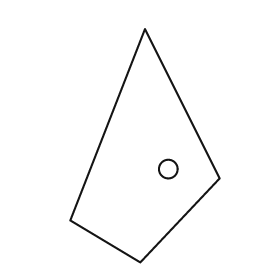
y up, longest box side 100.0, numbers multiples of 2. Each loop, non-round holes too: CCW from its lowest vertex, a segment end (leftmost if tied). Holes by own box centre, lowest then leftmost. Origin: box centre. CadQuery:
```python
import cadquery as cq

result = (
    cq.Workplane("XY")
    .moveTo(-2.0, -50.0)
    .lineTo(32.0, -14.0)
    .lineTo(0.0, 50.0)
    .lineTo(-32.0, -32.0)
    .close()
    .moveTo(10.0, -10.0)
    .circle(4.0)
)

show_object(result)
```